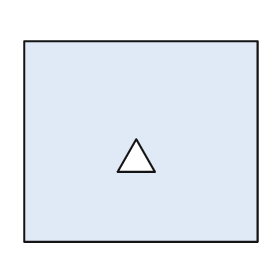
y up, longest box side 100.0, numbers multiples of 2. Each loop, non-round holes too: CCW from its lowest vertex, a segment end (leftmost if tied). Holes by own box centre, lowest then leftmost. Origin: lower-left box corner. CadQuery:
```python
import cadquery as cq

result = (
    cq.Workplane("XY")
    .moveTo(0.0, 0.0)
    .lineTo(100.0, 0.0)
    .lineTo(100.0, 86.0)
    .lineTo(0.0, 86.0)
    .close()
    .moveTo(40.0, 30.0)
    .lineTo(56.0, 30.0)
    .lineTo(48.0, 44.0)
    .close()
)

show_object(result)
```